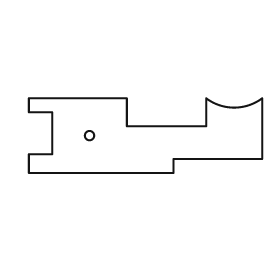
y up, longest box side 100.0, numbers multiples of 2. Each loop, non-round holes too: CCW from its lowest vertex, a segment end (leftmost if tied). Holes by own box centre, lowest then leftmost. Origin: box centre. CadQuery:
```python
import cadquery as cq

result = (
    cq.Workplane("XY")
    .moveTo(-50.0, -16.0)
    .lineTo(12.0, -16.0)
    .lineTo(12.0, -10.0)
    .lineTo(50.0, -10.0)
    .lineTo(50.0, 16.0)
    .threePointArc((38.0, 12.0), (26.0, 16.0))
    .lineTo(26.0, 4.0)
    .lineTo(-8.0, 4.0)
    .lineTo(-8.0, 16.0)
    .lineTo(-50.0, 16.0)
    .lineTo(-50.0, 10.0)
    .lineTo(-40.0, 10.0)
    .lineTo(-40.0, -8.0)
    .lineTo(-50.0, -8.0)
    .close()
    .moveTo(-24.0, 0.0)
    .circle(2.0)
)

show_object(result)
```